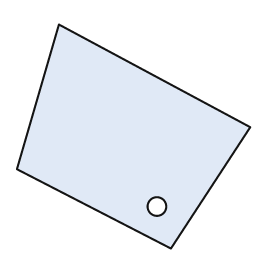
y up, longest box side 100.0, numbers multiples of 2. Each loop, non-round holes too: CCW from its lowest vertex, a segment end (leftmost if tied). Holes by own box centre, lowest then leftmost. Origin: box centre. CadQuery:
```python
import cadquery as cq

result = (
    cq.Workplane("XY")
    .moveTo(16.0, -48.0)
    .lineTo(50.0, 4.0)
    .lineTo(-32.0, 48.0)
    .lineTo(-50.0, -14.0)
    .close()
    .moveTo(10.0, -30.0)
    .circle(4.0)
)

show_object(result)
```